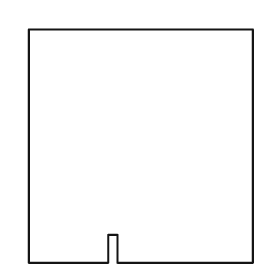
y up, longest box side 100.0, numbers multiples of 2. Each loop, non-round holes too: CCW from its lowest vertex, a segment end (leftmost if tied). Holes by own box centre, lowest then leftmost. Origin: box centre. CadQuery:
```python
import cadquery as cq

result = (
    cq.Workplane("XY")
    .moveTo(-48.0, -50.0)
    .lineTo(-14.0, -50.0)
    .lineTo(-14.0, -38.0)
    .lineTo(-10.0, -38.0)
    .lineTo(-10.0, -50.0)
    .lineTo(48.0, -50.0)
    .lineTo(48.0, 50.0)
    .lineTo(-48.0, 50.0)
    .close()
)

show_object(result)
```